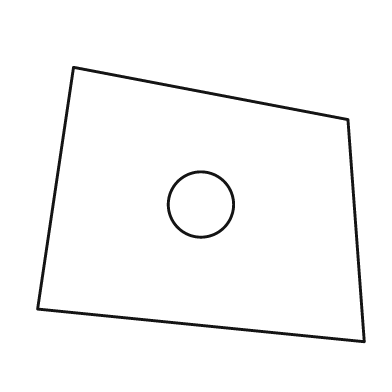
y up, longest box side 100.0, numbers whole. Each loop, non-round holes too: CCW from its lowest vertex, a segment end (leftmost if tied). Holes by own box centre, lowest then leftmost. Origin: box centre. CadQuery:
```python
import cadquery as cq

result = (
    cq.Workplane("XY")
    .moveTo(50.0, -42.0)
    .lineTo(45.0, 26.0)
    .lineTo(-39.0, 42.0)
    .lineTo(-50.0, -32.0)
    .close()
    .moveTo(0.0, 0.0)
    .circle(10.0)
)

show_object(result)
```